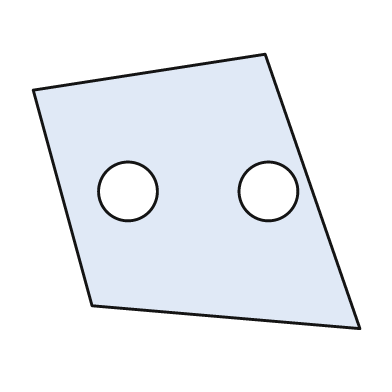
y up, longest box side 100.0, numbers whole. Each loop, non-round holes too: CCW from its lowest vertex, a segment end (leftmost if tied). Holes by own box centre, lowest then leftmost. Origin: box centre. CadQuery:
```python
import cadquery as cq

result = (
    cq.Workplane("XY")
    .moveTo(50.0, -42.0)
    .lineTo(21.0, 42.0)
    .lineTo(-50.0, 31.0)
    .lineTo(-32.0, -35.0)
    .close()
    .moveTo(-21.0, 0.0)
    .circle(9.0)
    .moveTo(22.0, 0.0)
    .circle(9.0)
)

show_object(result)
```